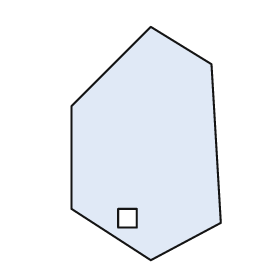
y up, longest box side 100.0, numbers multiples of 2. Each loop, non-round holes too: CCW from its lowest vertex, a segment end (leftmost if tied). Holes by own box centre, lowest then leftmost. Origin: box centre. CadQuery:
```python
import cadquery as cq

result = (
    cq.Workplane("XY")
    .moveTo(2.0, -50.0)
    .lineTo(32.0, -34.0)
    .lineTo(28.0, 34.0)
    .lineTo(2.0, 50.0)
    .lineTo(-32.0, 16.0)
    .lineTo(-32.0, -28.0)
    .close()
    .moveTo(-12.0, -36.0)
    .lineTo(-4.0, -36.0)
    .lineTo(-4.0, -28.0)
    .lineTo(-12.0, -28.0)
    .close()
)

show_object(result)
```